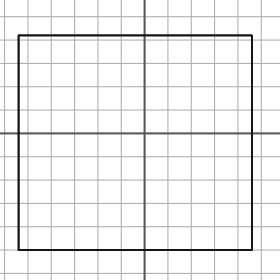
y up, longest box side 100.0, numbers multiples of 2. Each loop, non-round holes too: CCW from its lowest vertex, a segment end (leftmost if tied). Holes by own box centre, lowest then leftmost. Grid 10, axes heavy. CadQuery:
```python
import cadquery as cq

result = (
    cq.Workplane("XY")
    .moveTo(-54.0, -50.0)
    .lineTo(46.0, -50.0)
    .lineTo(46.0, 42.0)
    .lineTo(-54.0, 42.0)
    .close()
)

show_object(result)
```